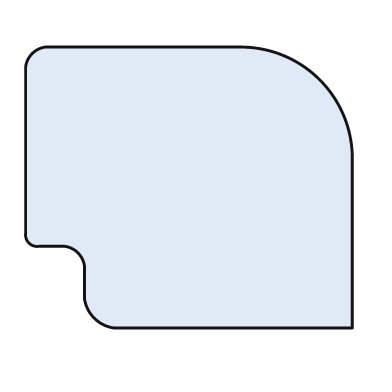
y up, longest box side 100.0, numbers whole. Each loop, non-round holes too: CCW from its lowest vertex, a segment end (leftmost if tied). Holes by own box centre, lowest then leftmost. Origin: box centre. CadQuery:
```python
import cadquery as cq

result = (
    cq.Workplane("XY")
    .moveTo(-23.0, -43.0)
    .lineTo(50.0, -43.0)
    .lineTo(50.0, 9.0)
    .threePointArc((40.0, 33.0), (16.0, 43.0))
    .lineTo(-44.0, 43.0)
    .threePointArc((-48.0, 41.0), (-50.0, 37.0))
    .lineTo(-50.0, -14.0)
    .threePointArc((-49.0, -17.0), (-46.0, -18.0))
    .lineTo(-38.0, -18.0)
    .threePointArc((-34.0, -20.0), (-32.0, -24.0))
    .lineTo(-32.0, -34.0)
    .threePointArc((-29.0, -40.0), (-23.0, -43.0))
    .close()
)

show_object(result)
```